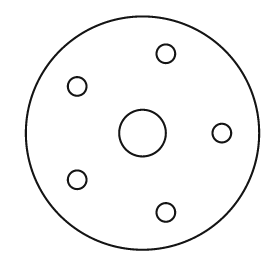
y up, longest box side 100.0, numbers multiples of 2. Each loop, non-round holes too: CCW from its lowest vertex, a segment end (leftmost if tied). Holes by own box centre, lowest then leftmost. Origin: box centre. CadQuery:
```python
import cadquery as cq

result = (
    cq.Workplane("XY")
    .moveTo(0.0, 0.0)
    .circle(50.0)
    .moveTo(10.0, -34.0)
    .circle(4.0)
    .moveTo(-28.0, -20.0)
    .circle(4.0)
    .moveTo(0.0, 0.0)
    .circle(10.0)
    .moveTo(34.0, 0.0)
    .circle(4.0)
    .moveTo(-28.0, 20.0)
    .circle(4.0)
    .moveTo(10.0, 34.0)
    .circle(4.0)
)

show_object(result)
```